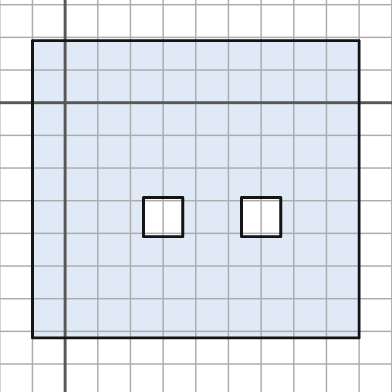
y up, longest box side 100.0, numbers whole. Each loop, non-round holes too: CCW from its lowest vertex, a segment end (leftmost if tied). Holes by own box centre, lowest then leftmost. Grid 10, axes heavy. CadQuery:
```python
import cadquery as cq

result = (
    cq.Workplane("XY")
    .moveTo(-10.0, -72.0)
    .lineTo(90.0, -72.0)
    .lineTo(90.0, 19.0)
    .lineTo(-10.0, 19.0)
    .close()
    .moveTo(24.0, -41.0)
    .lineTo(36.0, -41.0)
    .lineTo(36.0, -29.0)
    .lineTo(24.0, -29.0)
    .close()
    .moveTo(54.0, -41.0)
    .lineTo(66.0, -41.0)
    .lineTo(66.0, -29.0)
    .lineTo(54.0, -29.0)
    .close()
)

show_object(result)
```